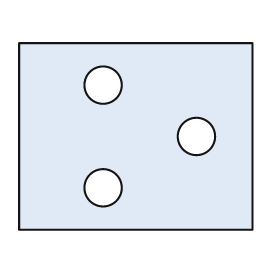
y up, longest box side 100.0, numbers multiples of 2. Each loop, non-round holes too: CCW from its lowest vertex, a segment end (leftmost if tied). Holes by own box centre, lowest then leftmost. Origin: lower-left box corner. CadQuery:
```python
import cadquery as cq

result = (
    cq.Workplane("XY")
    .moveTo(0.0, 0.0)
    .lineTo(100.0, 0.0)
    .lineTo(100.0, 80.0)
    .lineTo(0.0, 80.0)
    .close()
    .moveTo(36.0, 18.0)
    .circle(8.0)
    .moveTo(76.0, 40.0)
    .circle(8.0)
    .moveTo(36.0, 62.0)
    .circle(8.0)
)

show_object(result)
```